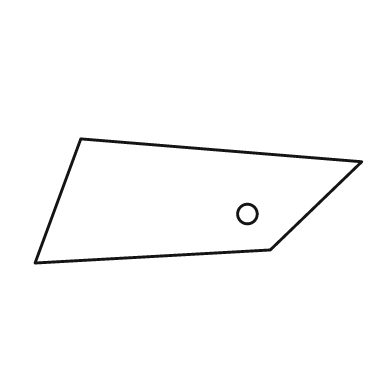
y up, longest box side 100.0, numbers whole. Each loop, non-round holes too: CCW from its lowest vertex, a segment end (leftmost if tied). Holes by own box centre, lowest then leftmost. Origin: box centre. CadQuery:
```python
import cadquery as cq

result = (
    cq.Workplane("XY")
    .moveTo(-50.0, -19.0)
    .lineTo(22.0, -15.0)
    .lineTo(50.0, 12.0)
    .lineTo(-36.0, 19.0)
    .close()
    .moveTo(15.0, -4.0)
    .circle(3.0)
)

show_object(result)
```